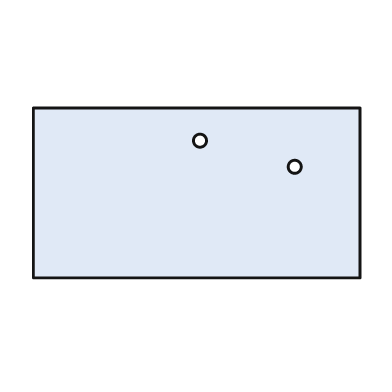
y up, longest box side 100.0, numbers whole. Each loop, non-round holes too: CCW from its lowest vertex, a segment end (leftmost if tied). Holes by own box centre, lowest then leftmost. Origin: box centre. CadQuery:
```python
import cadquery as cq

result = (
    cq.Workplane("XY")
    .moveTo(-50.0, -26.0)
    .lineTo(50.0, -26.0)
    .lineTo(50.0, 26.0)
    .lineTo(-50.0, 26.0)
    .close()
    .moveTo(30.0, 8.0)
    .circle(2.0)
    .moveTo(1.0, 16.0)
    .circle(2.0)
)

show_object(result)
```